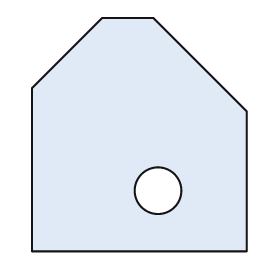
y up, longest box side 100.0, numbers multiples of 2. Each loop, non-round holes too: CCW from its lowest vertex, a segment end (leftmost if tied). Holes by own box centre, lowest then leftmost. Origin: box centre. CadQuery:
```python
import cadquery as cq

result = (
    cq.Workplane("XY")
    .moveTo(-46.0, -50.0)
    .lineTo(46.0, -50.0)
    .lineTo(46.0, 10.0)
    .lineTo(6.0, 50.0)
    .lineTo(-16.0, 50.0)
    .lineTo(-46.0, 20.0)
    .close()
    .moveTo(8.0, -24.0)
    .circle(10.0)
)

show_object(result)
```